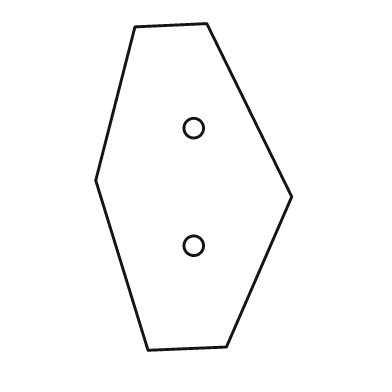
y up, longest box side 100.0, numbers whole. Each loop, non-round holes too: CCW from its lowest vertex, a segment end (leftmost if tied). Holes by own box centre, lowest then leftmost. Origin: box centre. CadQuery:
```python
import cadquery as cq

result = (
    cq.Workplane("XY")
    .moveTo(-14.0, -50.0)
    .lineTo(10.0, -49.0)
    .lineTo(30.0, -3.0)
    .lineTo(4.0, 50.0)
    .lineTo(-18.0, 49.0)
    .lineTo(-30.0, 2.0)
    .close()
    .moveTo(0.0, -18.0)
    .circle(3.0)
    .moveTo(0.0, 18.0)
    .circle(3.0)
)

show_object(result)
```